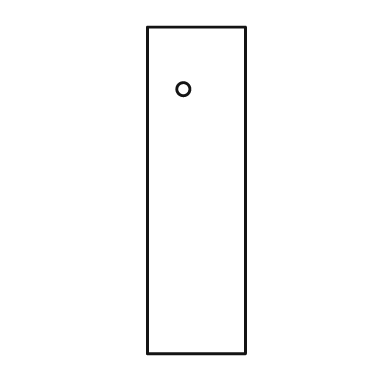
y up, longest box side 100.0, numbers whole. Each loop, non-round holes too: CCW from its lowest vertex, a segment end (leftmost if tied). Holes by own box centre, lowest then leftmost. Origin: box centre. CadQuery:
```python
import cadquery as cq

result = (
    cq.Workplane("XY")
    .moveTo(-15.0, -50.0)
    .lineTo(15.0, -50.0)
    .lineTo(15.0, 50.0)
    .lineTo(-15.0, 50.0)
    .close()
    .moveTo(-4.0, 31.0)
    .circle(2.0)
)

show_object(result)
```